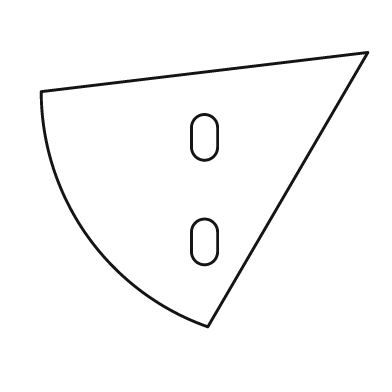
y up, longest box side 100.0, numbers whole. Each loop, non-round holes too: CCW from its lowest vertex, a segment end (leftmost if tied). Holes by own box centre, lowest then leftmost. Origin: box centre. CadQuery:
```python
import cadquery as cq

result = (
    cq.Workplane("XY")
    .moveTo(1.0, -42.0)
    .lineTo(50.0, 42.0)
    .lineTo(-50.0, 30.0)
    .threePointArc((-36.0, -14.0), (1.0, -42.0))
    .close()
    .moveTo(-4.0, -19.0)
    .threePointArc((0.0, -23.0), (4.0, -19.0))
    .lineTo(4.0, -13.0)
    .threePointArc((0.0, -9.0), (-4.0, -13.0))
    .close()
    .moveTo(-4.0, 13.0)
    .threePointArc((0.0, 9.0), (4.0, 13.0))
    .lineTo(4.0, 19.0)
    .threePointArc((0.0, 23.0), (-4.0, 19.0))
    .close()
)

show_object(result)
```